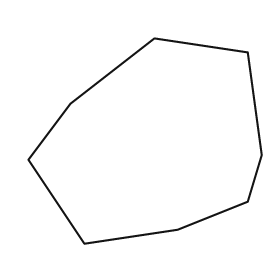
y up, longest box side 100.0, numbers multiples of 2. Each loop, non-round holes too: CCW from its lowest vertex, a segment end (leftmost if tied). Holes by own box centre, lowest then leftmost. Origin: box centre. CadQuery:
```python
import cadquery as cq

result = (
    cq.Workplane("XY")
    .moveTo(-26.0, -44.0)
    .lineTo(14.0, -38.0)
    .lineTo(44.0, -26.0)
    .lineTo(50.0, -6.0)
    .lineTo(44.0, 38.0)
    .lineTo(4.0, 44.0)
    .lineTo(-32.0, 16.0)
    .lineTo(-50.0, -8.0)
    .close()
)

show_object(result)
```